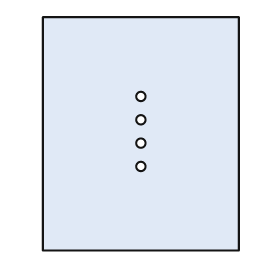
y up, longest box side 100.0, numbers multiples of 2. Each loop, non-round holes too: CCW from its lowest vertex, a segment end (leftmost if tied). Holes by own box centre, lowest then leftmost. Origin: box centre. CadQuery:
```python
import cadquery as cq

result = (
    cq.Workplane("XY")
    .moveTo(-42.0, -50.0)
    .lineTo(42.0, -50.0)
    .lineTo(42.0, 50.0)
    .lineTo(-42.0, 50.0)
    .close()
    .moveTo(0.0, -14.0)
    .circle(2.0)
    .moveTo(0.0, -4.0)
    .circle(2.0)
    .moveTo(0.0, 6.0)
    .circle(2.0)
    .moveTo(0.0, 16.0)
    .circle(2.0)
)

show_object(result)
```